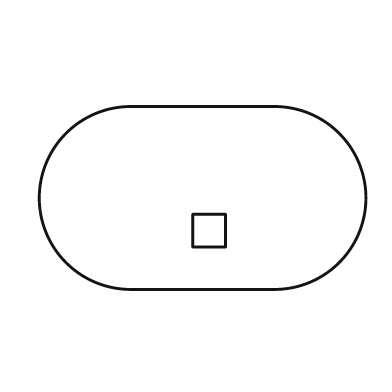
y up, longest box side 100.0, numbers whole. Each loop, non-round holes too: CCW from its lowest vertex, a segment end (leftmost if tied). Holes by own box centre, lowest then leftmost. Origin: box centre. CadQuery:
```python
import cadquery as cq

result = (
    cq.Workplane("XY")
    .moveTo(-22.0, -28.0)
    .lineTo(22.0, -28.0)
    .threePointArc((50.0, 0.0), (22.0, 28.0))
    .lineTo(-22.0, 28.0)
    .threePointArc((-50.0, 0.0), (-22.0, -28.0))
    .close()
    .moveTo(-3.0, -15.0)
    .lineTo(7.0, -15.0)
    .lineTo(7.0, -5.0)
    .lineTo(-3.0, -5.0)
    .close()
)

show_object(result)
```